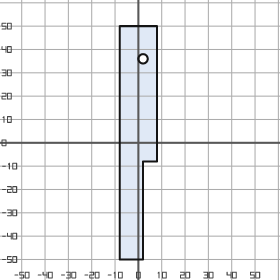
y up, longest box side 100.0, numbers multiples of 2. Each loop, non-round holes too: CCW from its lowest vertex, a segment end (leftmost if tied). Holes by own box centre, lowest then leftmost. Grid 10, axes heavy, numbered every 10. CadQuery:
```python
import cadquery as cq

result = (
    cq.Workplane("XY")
    .moveTo(-8.0, -50.0)
    .lineTo(2.0, -50.0)
    .lineTo(2.0, -8.0)
    .lineTo(8.0, -8.0)
    .lineTo(8.0, 50.0)
    .lineTo(-8.0, 50.0)
    .close()
    .moveTo(2.0, 36.0)
    .circle(2.0)
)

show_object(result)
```